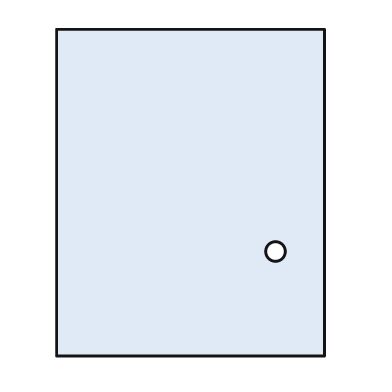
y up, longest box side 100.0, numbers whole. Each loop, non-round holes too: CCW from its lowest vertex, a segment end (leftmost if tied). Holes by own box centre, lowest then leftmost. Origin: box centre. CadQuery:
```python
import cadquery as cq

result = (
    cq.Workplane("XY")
    .moveTo(-41.0, -50.0)
    .lineTo(41.0, -50.0)
    .lineTo(41.0, 50.0)
    .lineTo(-41.0, 50.0)
    .close()
    .moveTo(26.0, -18.0)
    .circle(3.0)
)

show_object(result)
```